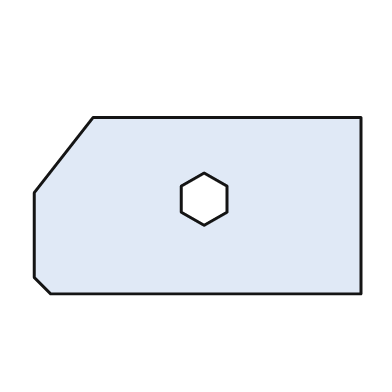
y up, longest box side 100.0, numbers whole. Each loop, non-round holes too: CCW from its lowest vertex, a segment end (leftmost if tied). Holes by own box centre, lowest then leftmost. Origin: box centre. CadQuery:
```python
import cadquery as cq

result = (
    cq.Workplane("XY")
    .moveTo(-45.0, -27.0)
    .lineTo(50.0, -27.0)
    .lineTo(50.0, 27.0)
    .lineTo(-32.0, 27.0)
    .lineTo(-50.0, 4.0)
    .lineTo(-50.0, -22.0)
    .close()
    .moveTo(2.0, -6.0)
    .lineTo(9.0, -2.0)
    .lineTo(9.0, 6.0)
    .lineTo(2.0, 10.0)
    .lineTo(-5.0, 6.0)
    .lineTo(-5.0, -2.0)
    .close()
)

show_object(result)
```